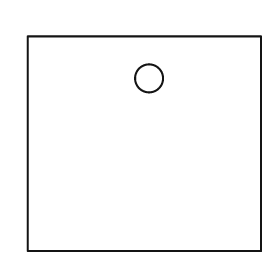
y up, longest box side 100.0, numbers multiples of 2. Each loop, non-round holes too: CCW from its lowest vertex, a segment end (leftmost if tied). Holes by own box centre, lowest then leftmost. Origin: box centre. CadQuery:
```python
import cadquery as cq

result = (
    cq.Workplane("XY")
    .moveTo(-50.0, -46.0)
    .lineTo(50.0, -46.0)
    .lineTo(50.0, 46.0)
    .lineTo(-50.0, 46.0)
    .close()
    .moveTo(2.0, 28.0)
    .circle(6.0)
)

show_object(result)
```